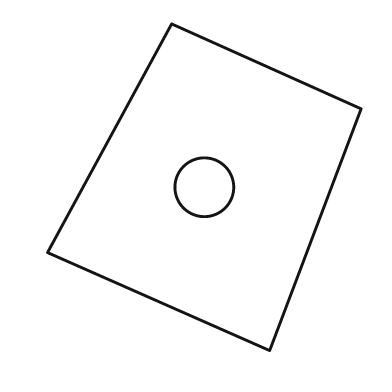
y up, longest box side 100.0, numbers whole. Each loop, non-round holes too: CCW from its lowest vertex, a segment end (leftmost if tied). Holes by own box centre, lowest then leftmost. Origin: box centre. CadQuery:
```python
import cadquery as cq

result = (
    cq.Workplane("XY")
    .moveTo(20.0, -50.0)
    .lineTo(48.0, 24.0)
    .lineTo(-10.0, 50.0)
    .lineTo(-48.0, -20.0)
    .close()
    .moveTo(0.0, 0.0)
    .circle(9.0)
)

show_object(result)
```